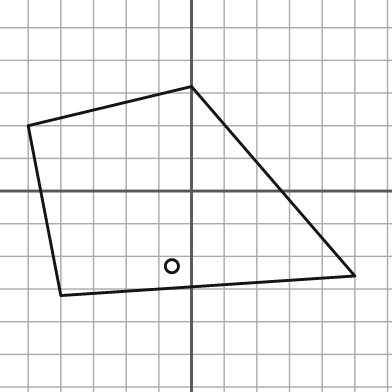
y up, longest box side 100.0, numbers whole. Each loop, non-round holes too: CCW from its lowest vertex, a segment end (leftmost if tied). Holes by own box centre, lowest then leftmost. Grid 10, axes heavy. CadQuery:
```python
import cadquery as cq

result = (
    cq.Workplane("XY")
    .moveTo(-40.0, -32.0)
    .lineTo(50.0, -26.0)
    .lineTo(0.0, 32.0)
    .lineTo(-50.0, 20.0)
    .close()
    .moveTo(-6.0, -23.0)
    .circle(2.0)
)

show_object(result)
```